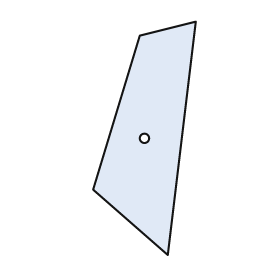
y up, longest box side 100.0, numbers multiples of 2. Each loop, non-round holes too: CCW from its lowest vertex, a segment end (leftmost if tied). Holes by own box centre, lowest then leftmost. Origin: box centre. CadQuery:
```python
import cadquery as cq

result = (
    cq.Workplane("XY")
    .moveTo(10.0, -50.0)
    .lineTo(22.0, 50.0)
    .lineTo(-2.0, 44.0)
    .lineTo(-22.0, -22.0)
    .close()
    .moveTo(0.0, 0.0)
    .circle(2.0)
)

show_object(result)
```